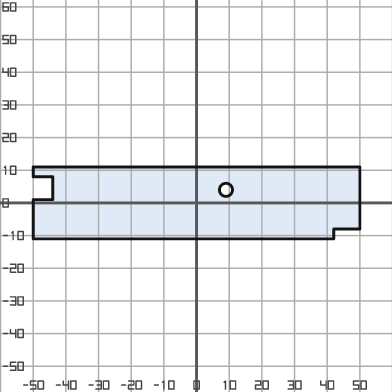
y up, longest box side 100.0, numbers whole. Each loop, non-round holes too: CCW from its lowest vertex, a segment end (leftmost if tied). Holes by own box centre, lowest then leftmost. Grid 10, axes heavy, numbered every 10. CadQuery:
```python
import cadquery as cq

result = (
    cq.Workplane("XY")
    .moveTo(-50.0, -11.0)
    .lineTo(42.0, -11.0)
    .lineTo(42.0, -8.0)
    .lineTo(50.0, -8.0)
    .lineTo(50.0, 11.0)
    .lineTo(-50.0, 11.0)
    .lineTo(-50.0, 8.0)
    .lineTo(-44.0, 8.0)
    .lineTo(-44.0, 1.0)
    .lineTo(-50.0, 1.0)
    .close()
    .moveTo(9.0, 4.0)
    .circle(2.0)
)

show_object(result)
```